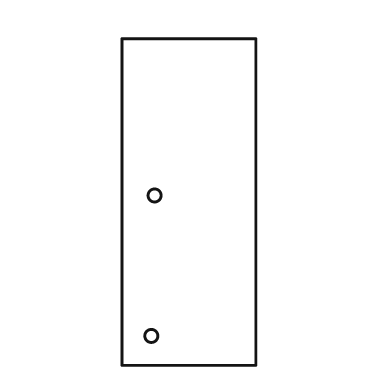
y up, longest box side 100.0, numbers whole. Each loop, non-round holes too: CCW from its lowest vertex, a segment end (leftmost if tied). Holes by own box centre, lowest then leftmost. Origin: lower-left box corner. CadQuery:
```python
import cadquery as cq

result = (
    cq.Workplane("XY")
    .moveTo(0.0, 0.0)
    .lineTo(41.0, 0.0)
    .lineTo(41.0, 100.0)
    .lineTo(0.0, 100.0)
    .close()
    .moveTo(9.0, 9.0)
    .circle(2.0)
    .moveTo(10.0, 52.0)
    .circle(2.0)
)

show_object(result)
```